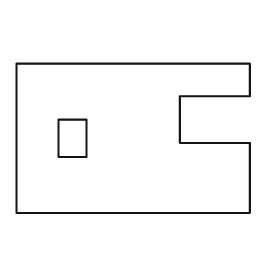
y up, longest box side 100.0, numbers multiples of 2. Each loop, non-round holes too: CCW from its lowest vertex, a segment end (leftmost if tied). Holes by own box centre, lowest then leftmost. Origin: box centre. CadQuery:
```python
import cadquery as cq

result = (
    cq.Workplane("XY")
    .moveTo(-50.0, -32.0)
    .lineTo(50.0, -32.0)
    .lineTo(50.0, -2.0)
    .lineTo(20.0, -2.0)
    .lineTo(20.0, 18.0)
    .lineTo(50.0, 18.0)
    .lineTo(50.0, 32.0)
    .lineTo(-50.0, 32.0)
    .close()
    .moveTo(-32.0, -8.0)
    .lineTo(-20.0, -8.0)
    .lineTo(-20.0, 8.0)
    .lineTo(-32.0, 8.0)
    .close()
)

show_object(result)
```